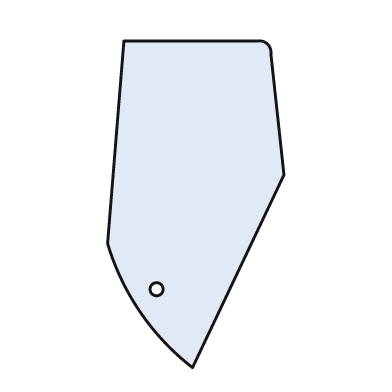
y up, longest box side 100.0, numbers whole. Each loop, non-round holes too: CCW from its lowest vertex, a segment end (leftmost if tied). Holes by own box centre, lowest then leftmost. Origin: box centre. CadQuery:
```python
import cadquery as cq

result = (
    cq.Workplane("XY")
    .moveTo(-1.0, -50.0)
    .lineTo(27.0, 9.0)
    .lineTo(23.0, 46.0)
    .threePointArc((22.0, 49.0), (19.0, 50.0))
    .lineTo(-22.0, 50.0)
    .lineTo(-27.0, -12.0)
    .threePointArc((-17.0, -33.0), (-1.0, -50.0))
    .close()
    .moveTo(-12.0, -26.0)
    .circle(2.0)
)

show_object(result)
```